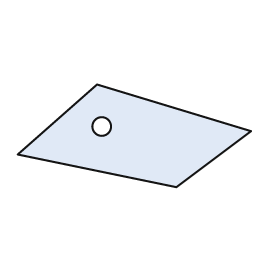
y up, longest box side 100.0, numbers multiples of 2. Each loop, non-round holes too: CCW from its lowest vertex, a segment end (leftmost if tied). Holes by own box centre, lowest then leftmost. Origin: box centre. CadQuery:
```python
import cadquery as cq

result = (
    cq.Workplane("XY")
    .moveTo(18.0, -22.0)
    .lineTo(50.0, 2.0)
    .lineTo(-16.0, 22.0)
    .lineTo(-50.0, -8.0)
    .close()
    .moveTo(-14.0, 4.0)
    .circle(4.0)
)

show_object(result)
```